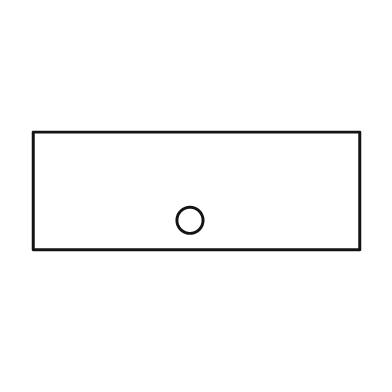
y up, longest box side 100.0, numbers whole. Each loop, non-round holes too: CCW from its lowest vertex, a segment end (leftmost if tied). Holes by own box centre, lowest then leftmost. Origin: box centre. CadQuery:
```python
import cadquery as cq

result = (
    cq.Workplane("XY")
    .moveTo(-50.0, -18.0)
    .lineTo(50.0, -18.0)
    .lineTo(50.0, 18.0)
    .lineTo(-50.0, 18.0)
    .close()
    .moveTo(-2.0, -9.0)
    .circle(4.0)
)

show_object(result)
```